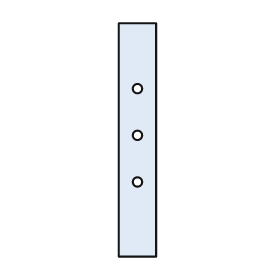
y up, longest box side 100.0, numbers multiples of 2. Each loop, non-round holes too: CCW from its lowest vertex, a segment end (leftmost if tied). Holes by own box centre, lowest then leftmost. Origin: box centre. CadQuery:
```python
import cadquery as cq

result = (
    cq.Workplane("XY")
    .moveTo(-8.0, -50.0)
    .lineTo(8.0, -50.0)
    .lineTo(8.0, 50.0)
    .lineTo(-8.0, 50.0)
    .close()
    .moveTo(0.0, -18.0)
    .circle(2.0)
    .moveTo(0.0, 2.0)
    .circle(2.0)
    .moveTo(0.0, 22.0)
    .circle(2.0)
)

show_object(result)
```